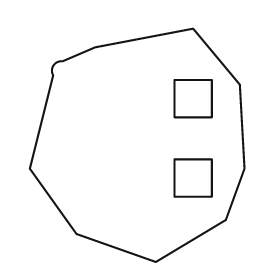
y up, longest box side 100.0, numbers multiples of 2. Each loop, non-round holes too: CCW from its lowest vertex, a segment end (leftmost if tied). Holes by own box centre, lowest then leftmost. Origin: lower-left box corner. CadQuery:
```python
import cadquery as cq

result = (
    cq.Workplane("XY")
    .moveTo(54.0, 0.0)
    .lineTo(84.0, 18.0)
    .lineTo(92.0, 40.0)
    .lineTo(90.0, 76.0)
    .lineTo(70.0, 100.0)
    .lineTo(28.0, 92.0)
    .lineTo(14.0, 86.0)
    .threePointArc((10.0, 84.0), (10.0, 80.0))
    .lineTo(0.0, 40.0)
    .lineTo(20.0, 12.0)
    .close()
    .moveTo(62.0, 28.0)
    .lineTo(78.0, 28.0)
    .lineTo(78.0, 44.0)
    .lineTo(62.0, 44.0)
    .close()
    .moveTo(62.0, 62.0)
    .lineTo(78.0, 62.0)
    .lineTo(78.0, 78.0)
    .lineTo(62.0, 78.0)
    .close()
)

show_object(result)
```